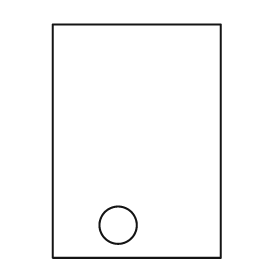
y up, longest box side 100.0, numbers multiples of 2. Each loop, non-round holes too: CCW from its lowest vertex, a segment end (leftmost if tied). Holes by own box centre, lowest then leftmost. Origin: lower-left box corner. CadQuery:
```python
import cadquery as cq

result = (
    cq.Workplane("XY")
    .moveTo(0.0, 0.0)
    .lineTo(72.0, 0.0)
    .lineTo(72.0, 100.0)
    .lineTo(0.0, 100.0)
    .close()
    .moveTo(28.0, 14.0)
    .circle(8.0)
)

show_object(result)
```